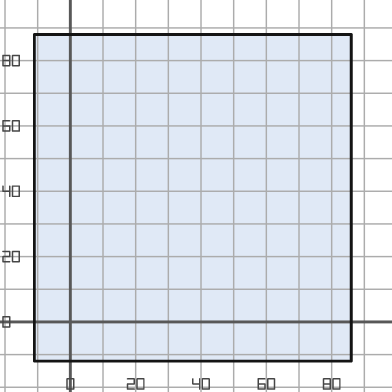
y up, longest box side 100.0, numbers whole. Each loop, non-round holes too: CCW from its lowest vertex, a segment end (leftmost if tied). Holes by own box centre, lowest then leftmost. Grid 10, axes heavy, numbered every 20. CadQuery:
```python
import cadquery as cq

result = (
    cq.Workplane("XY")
    .moveTo(-11.0, -12.0)
    .lineTo(86.0, -12.0)
    .lineTo(86.0, 88.0)
    .lineTo(-11.0, 88.0)
    .close()
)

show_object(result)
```